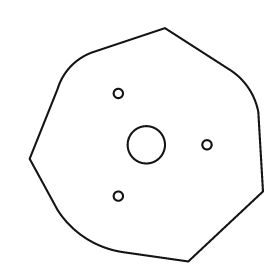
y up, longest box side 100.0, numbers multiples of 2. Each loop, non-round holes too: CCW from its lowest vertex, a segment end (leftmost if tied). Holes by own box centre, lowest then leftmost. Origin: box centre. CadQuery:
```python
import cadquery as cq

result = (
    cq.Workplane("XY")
    .moveTo(18.0, -50.0)
    .lineTo(50.0, -20.0)
    .lineTo(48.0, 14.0)
    .threePointArc((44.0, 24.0), (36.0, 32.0))
    .lineTo(8.0, 50.0)
    .lineTo(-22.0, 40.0)
    .threePointArc((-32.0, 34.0), (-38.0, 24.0))
    .lineTo(-50.0, -6.0)
    .lineTo(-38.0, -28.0)
    .threePointArc((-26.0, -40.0), (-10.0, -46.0))
    .close()
    .moveTo(-12.0, -22.0)
    .circle(2.0)
    .moveTo(0.0, 0.0)
    .circle(8.0)
    .moveTo(26.0, 0.0)
    .circle(2.0)
    .moveTo(-12.0, 22.0)
    .circle(2.0)
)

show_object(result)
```